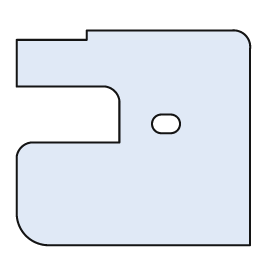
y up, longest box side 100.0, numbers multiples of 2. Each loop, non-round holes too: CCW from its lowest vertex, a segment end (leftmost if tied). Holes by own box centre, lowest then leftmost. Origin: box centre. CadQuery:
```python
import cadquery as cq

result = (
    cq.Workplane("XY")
    .moveTo(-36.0, -46.0)
    .lineTo(50.0, -46.0)
    .lineTo(50.0, 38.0)
    .threePointArc((48.0, 44.0), (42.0, 46.0))
    .lineTo(-20.0, 46.0)
    .lineTo(-20.0, 42.0)
    .lineTo(-50.0, 42.0)
    .lineTo(-50.0, 22.0)
    .lineTo(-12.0, 22.0)
    .threePointArc((-8.0, 20.0), (-6.0, 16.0))
    .lineTo(-6.0, -2.0)
    .lineTo(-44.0, -2.0)
    .threePointArc((-48.0, -4.0), (-50.0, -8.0))
    .lineTo(-50.0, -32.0)
    .threePointArc((-46.0, -42.0), (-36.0, -46.0))
    .close()
    .moveTo(12.0, 2.0)
    .lineTo(16.0, 2.0)
    .threePointArc((20.0, 6.0), (16.0, 10.0))
    .lineTo(12.0, 10.0)
    .threePointArc((8.0, 6.0), (12.0, 2.0))
    .close()
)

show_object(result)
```